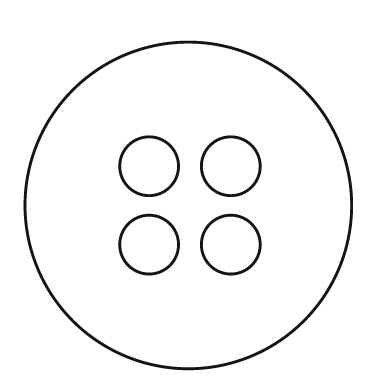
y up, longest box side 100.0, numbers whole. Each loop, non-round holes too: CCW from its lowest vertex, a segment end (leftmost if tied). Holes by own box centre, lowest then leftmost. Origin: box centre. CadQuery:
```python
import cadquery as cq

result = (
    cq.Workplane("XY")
    .moveTo(0.0, 0.0)
    .circle(50.0)
    .moveTo(-12.0, -12.0)
    .circle(9.0)
    .moveTo(13.0, -12.0)
    .circle(9.0)
    .moveTo(-12.0, 12.0)
    .circle(9.0)
    .moveTo(13.0, 12.0)
    .circle(9.0)
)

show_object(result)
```